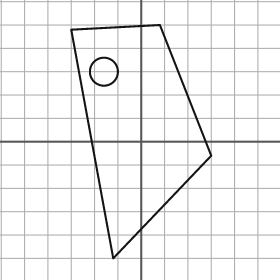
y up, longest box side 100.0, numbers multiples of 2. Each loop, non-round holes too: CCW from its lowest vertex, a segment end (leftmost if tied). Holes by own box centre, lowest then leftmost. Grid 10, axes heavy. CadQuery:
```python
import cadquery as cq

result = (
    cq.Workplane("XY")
    .moveTo(-12.0, -50.0)
    .lineTo(30.0, -6.0)
    .lineTo(8.0, 50.0)
    .lineTo(-30.0, 48.0)
    .close()
    .moveTo(-16.0, 30.0)
    .circle(6.0)
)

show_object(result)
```